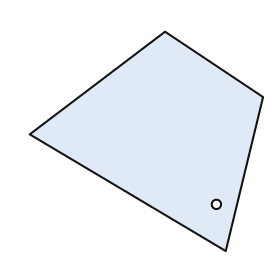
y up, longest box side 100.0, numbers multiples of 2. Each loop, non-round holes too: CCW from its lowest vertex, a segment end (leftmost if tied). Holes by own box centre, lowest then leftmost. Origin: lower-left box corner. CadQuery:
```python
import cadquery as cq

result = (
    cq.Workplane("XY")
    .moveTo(84.0, 0.0)
    .lineTo(100.0, 66.0)
    .lineTo(58.0, 94.0)
    .lineTo(0.0, 50.0)
    .close()
    .moveTo(80.0, 20.0)
    .circle(2.0)
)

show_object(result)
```